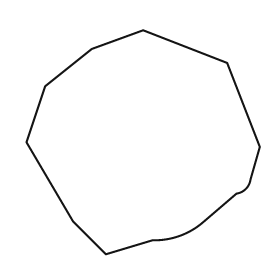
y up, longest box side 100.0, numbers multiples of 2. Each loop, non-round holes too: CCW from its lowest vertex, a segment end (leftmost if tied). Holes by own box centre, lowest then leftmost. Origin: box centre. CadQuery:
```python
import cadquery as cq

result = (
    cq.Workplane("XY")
    .moveTo(-16.0, -48.0)
    .lineTo(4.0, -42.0)
    .threePointArc((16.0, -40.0), (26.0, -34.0))
    .lineTo(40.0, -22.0)
    .threePointArc((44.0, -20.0), (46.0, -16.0))
    .lineTo(50.0, -2.0)
    .lineTo(36.0, 34.0)
    .lineTo(0.0, 48.0)
    .lineTo(-22.0, 40.0)
    .lineTo(-42.0, 24.0)
    .lineTo(-50.0, 0.0)
    .lineTo(-30.0, -34.0)
    .close()
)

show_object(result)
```